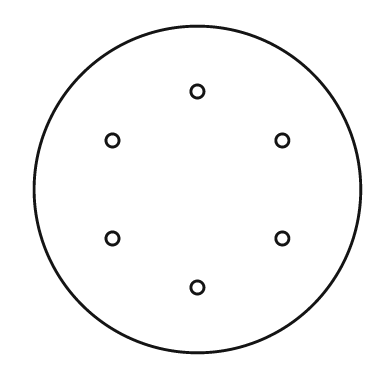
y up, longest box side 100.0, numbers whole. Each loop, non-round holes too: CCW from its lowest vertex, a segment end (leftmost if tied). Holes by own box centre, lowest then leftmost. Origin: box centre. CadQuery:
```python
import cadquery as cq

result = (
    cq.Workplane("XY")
    .moveTo(0.0, 0.0)
    .circle(50.0)
    .moveTo(0.0, -30.0)
    .circle(2.0)
    .moveTo(-26.0, -15.0)
    .circle(2.0)
    .moveTo(26.0, -15.0)
    .circle(2.0)
    .moveTo(-26.0, 15.0)
    .circle(2.0)
    .moveTo(26.0, 15.0)
    .circle(2.0)
    .moveTo(0.0, 30.0)
    .circle(2.0)
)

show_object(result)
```